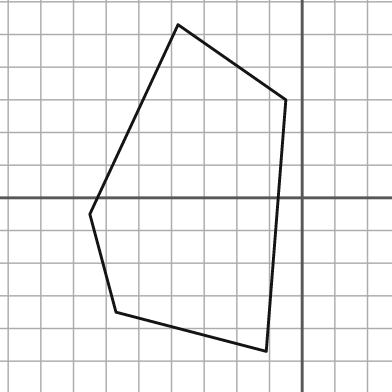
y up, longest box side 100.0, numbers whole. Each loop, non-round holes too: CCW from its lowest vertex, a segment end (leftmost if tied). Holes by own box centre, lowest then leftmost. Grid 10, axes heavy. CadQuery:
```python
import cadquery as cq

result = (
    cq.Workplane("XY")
    .moveTo(-11.0, -47.0)
    .lineTo(-5.0, 30.0)
    .lineTo(-38.0, 53.0)
    .lineTo(-65.0, -5.0)
    .lineTo(-57.0, -35.0)
    .close()
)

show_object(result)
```